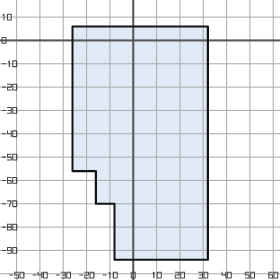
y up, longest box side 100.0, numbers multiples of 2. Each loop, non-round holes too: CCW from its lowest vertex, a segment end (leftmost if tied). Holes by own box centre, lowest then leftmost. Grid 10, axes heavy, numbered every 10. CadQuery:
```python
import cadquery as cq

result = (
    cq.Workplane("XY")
    .moveTo(-8.0, -94.0)
    .lineTo(32.0, -94.0)
    .lineTo(32.0, 6.0)
    .lineTo(-26.0, 6.0)
    .lineTo(-26.0, -56.0)
    .lineTo(-16.0, -56.0)
    .lineTo(-16.0, -70.0)
    .lineTo(-8.0, -70.0)
    .close()
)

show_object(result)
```